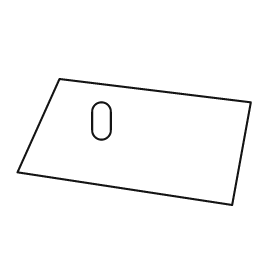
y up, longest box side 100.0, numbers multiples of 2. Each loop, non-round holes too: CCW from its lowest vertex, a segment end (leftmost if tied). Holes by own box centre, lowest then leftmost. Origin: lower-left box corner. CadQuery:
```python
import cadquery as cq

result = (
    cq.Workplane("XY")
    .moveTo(92.0, 0.0)
    .lineTo(100.0, 44.0)
    .lineTo(18.0, 54.0)
    .lineTo(0.0, 14.0)
    .close()
    .moveTo(32.0, 32.0)
    .threePointArc((36.0, 28.0), (40.0, 32.0))
    .lineTo(40.0, 40.0)
    .threePointArc((36.0, 44.0), (32.0, 40.0))
    .close()
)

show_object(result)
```